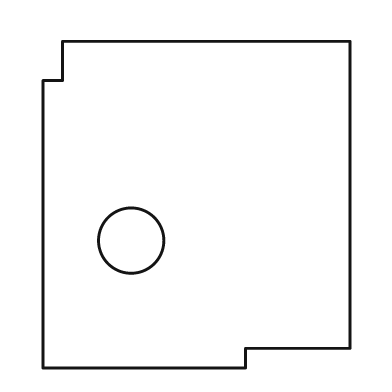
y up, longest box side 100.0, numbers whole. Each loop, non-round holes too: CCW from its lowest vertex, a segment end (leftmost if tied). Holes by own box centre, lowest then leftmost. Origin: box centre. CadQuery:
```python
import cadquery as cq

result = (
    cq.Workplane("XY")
    .moveTo(-47.0, -50.0)
    .lineTo(15.0, -50.0)
    .lineTo(15.0, -44.0)
    .lineTo(47.0, -44.0)
    .lineTo(47.0, 50.0)
    .lineTo(-41.0, 50.0)
    .lineTo(-41.0, 38.0)
    .lineTo(-47.0, 38.0)
    .close()
    .moveTo(-20.0, -11.0)
    .circle(10.0)
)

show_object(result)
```